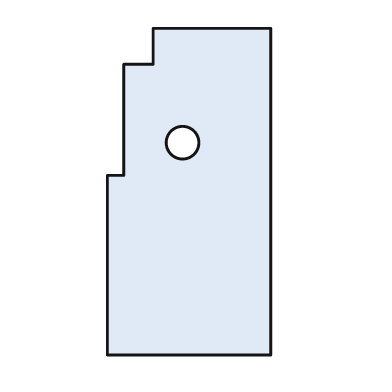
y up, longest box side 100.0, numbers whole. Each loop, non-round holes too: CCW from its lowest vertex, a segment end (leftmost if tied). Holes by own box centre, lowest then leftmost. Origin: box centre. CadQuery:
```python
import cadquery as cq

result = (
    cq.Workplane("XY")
    .moveTo(-25.0, -50.0)
    .lineTo(25.0, -50.0)
    .lineTo(25.0, 50.0)
    .lineTo(-11.0, 50.0)
    .lineTo(-11.0, 39.0)
    .lineTo(-20.0, 39.0)
    .lineTo(-20.0, 5.0)
    .lineTo(-25.0, 5.0)
    .close()
    .moveTo(-2.0, 15.0)
    .circle(5.0)
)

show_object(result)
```